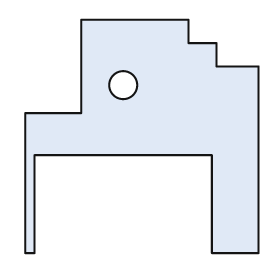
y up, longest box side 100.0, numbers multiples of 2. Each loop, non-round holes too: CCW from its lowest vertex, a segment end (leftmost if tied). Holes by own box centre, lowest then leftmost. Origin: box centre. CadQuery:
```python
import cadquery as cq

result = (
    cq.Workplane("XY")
    .moveTo(-50.0, -50.0)
    .lineTo(-46.0, -50.0)
    .lineTo(-46.0, -8.0)
    .lineTo(30.0, -8.0)
    .lineTo(30.0, -50.0)
    .lineTo(50.0, -50.0)
    .lineTo(50.0, 30.0)
    .lineTo(32.0, 30.0)
    .lineTo(32.0, 40.0)
    .lineTo(20.0, 40.0)
    .lineTo(20.0, 50.0)
    .lineTo(-26.0, 50.0)
    .lineTo(-26.0, 10.0)
    .lineTo(-50.0, 10.0)
    .close()
    .moveTo(-8.0, 22.0)
    .circle(6.0)
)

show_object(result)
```